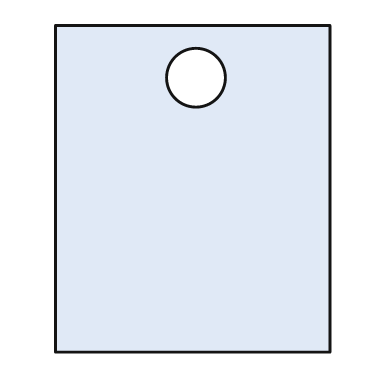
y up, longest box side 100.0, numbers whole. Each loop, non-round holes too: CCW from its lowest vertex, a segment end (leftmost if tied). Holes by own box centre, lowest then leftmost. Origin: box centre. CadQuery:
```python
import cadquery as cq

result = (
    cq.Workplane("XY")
    .moveTo(-42.0, -50.0)
    .lineTo(42.0, -50.0)
    .lineTo(42.0, 50.0)
    .lineTo(-42.0, 50.0)
    .close()
    .moveTo(1.0, 34.0)
    .circle(9.0)
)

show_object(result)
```